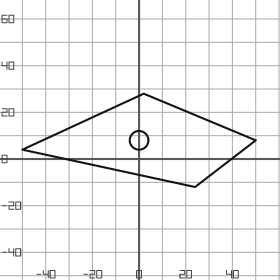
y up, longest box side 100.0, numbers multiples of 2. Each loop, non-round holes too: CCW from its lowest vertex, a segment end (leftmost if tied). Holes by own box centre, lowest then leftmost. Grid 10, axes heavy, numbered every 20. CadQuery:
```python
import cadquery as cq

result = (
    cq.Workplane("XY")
    .moveTo(24.0, -12.0)
    .lineTo(50.0, 8.0)
    .lineTo(2.0, 28.0)
    .lineTo(-50.0, 4.0)
    .close()
    .moveTo(0.0, 8.0)
    .circle(4.0)
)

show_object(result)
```